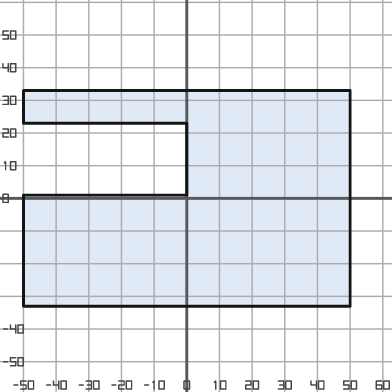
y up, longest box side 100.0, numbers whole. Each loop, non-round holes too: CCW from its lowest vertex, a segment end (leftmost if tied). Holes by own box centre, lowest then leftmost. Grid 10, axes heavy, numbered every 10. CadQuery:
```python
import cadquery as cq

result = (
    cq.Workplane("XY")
    .moveTo(-50.0, -33.0)
    .lineTo(50.0, -33.0)
    .lineTo(50.0, 33.0)
    .lineTo(-50.0, 33.0)
    .lineTo(-50.0, 23.0)
    .lineTo(0.0, 23.0)
    .lineTo(0.0, 1.0)
    .lineTo(-50.0, 1.0)
    .close()
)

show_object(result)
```